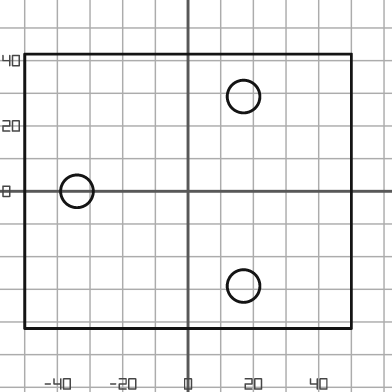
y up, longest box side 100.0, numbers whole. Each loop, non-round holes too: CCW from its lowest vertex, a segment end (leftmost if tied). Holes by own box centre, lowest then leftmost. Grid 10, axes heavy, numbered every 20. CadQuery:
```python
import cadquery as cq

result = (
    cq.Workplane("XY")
    .moveTo(-50.0, -42.0)
    .lineTo(50.0, -42.0)
    .lineTo(50.0, 42.0)
    .lineTo(-50.0, 42.0)
    .close()
    .moveTo(17.0, -29.0)
    .circle(5.0)
    .moveTo(-34.0, 0.0)
    .circle(5.0)
    .moveTo(17.0, 29.0)
    .circle(5.0)
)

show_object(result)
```